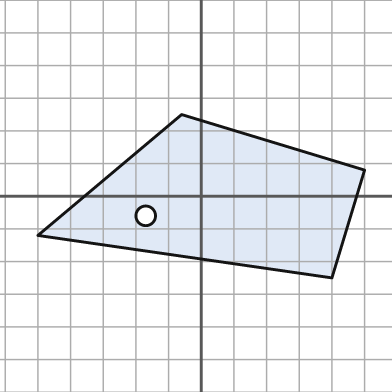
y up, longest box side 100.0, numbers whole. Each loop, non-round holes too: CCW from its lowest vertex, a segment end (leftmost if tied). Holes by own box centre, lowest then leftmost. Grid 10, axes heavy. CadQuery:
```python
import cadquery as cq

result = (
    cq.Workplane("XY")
    .moveTo(40.0, -25.0)
    .lineTo(50.0, 8.0)
    .lineTo(-6.0, 25.0)
    .lineTo(-50.0, -12.0)
    .close()
    .moveTo(-17.0, -6.0)
    .circle(3.0)
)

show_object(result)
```